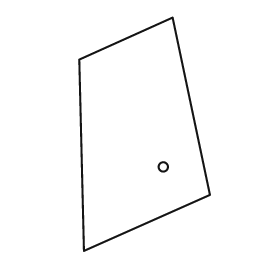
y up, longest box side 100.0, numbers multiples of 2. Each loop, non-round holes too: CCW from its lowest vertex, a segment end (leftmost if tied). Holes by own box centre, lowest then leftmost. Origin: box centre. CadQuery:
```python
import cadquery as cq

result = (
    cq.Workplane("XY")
    .moveTo(-26.0, -50.0)
    .lineTo(28.0, -26.0)
    .lineTo(12.0, 50.0)
    .lineTo(-28.0, 32.0)
    .close()
    .moveTo(8.0, -14.0)
    .circle(2.0)
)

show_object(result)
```